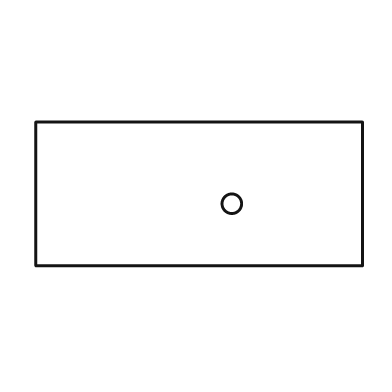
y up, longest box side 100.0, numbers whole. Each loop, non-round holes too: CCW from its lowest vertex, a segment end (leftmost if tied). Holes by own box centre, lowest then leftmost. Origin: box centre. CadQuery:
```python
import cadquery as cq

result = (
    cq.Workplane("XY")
    .moveTo(-50.0, -22.0)
    .lineTo(50.0, -22.0)
    .lineTo(50.0, 22.0)
    .lineTo(-50.0, 22.0)
    .close()
    .moveTo(10.0, -3.0)
    .circle(3.0)
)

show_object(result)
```